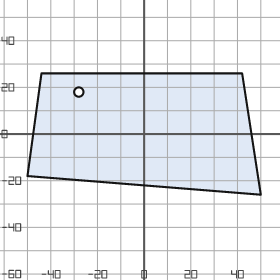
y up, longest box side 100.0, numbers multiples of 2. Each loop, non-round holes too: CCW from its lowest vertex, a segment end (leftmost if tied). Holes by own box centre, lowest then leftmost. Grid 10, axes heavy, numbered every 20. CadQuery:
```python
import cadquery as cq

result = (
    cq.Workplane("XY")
    .moveTo(50.0, -26.0)
    .lineTo(42.0, 26.0)
    .lineTo(-44.0, 26.0)
    .lineTo(-50.0, -18.0)
    .close()
    .moveTo(-28.0, 18.0)
    .circle(2.0)
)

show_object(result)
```